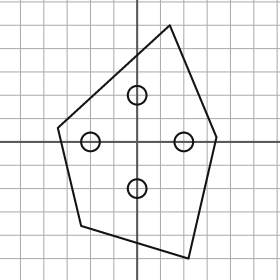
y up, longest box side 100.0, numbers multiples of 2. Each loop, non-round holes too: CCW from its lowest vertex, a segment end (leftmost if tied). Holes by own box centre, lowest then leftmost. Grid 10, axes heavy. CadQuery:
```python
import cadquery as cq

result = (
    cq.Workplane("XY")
    .moveTo(22.0, -50.0)
    .lineTo(34.0, 2.0)
    .lineTo(14.0, 50.0)
    .lineTo(-34.0, 6.0)
    .lineTo(-24.0, -36.0)
    .close()
    .moveTo(0.0, -20.0)
    .circle(4.0)
    .moveTo(-20.0, 0.0)
    .circle(4.0)
    .moveTo(20.0, 0.0)
    .circle(4.0)
    .moveTo(0.0, 20.0)
    .circle(4.0)
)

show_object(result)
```